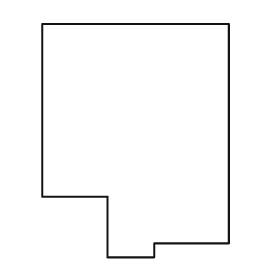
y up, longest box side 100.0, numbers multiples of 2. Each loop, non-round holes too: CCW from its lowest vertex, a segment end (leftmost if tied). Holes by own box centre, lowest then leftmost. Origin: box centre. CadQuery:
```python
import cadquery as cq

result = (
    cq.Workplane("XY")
    .moveTo(-12.0, -50.0)
    .lineTo(8.0, -50.0)
    .lineTo(8.0, -44.0)
    .lineTo(40.0, -44.0)
    .lineTo(40.0, 50.0)
    .lineTo(-40.0, 50.0)
    .lineTo(-40.0, -24.0)
    .lineTo(-12.0, -24.0)
    .close()
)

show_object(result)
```